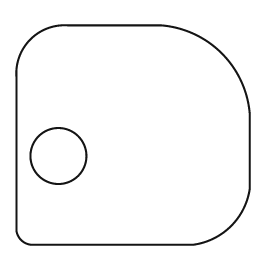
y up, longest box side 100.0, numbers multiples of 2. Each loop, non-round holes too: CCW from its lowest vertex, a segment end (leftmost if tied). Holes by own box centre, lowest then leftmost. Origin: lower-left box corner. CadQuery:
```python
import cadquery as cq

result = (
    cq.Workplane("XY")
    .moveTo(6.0, 0.0)
    .lineTo(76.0, 0.0)
    .threePointArc((92.0, 8.0), (100.0, 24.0))
    .lineTo(100.0, 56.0)
    .threePointArc((88.0, 82.0), (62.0, 94.0))
    .lineTo(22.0, 94.0)
    .threePointArc((6.0, 88.0), (0.0, 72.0))
    .lineTo(0.0, 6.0)
    .threePointArc((2.0, 2.0), (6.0, 0.0))
    .close()
    .moveTo(18.0, 38.0)
    .circle(12.0)
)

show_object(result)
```